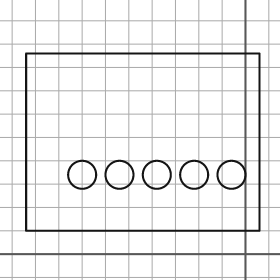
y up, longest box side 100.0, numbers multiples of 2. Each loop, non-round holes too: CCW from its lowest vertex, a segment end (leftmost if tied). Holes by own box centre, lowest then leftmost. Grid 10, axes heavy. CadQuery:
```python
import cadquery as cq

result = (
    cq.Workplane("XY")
    .moveTo(-94.0, 10.0)
    .lineTo(6.0, 10.0)
    .lineTo(6.0, 86.0)
    .lineTo(-94.0, 86.0)
    .close()
    .moveTo(-70.0, 34.0)
    .circle(6.0)
    .moveTo(-54.0, 34.0)
    .circle(6.0)
    .moveTo(-38.0, 34.0)
    .circle(6.0)
    .moveTo(-22.0, 34.0)
    .circle(6.0)
    .moveTo(-6.0, 34.0)
    .circle(6.0)
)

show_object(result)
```